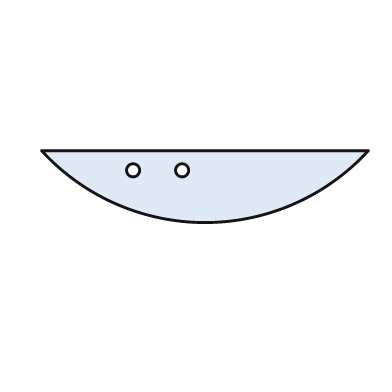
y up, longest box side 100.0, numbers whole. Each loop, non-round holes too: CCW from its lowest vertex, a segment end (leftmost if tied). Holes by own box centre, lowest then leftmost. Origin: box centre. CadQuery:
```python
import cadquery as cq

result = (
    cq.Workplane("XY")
    .moveTo(-50.0, 11.0)
    .threePointArc((0.0, -11.0), (50.0, 11.0))
    .close()
    .moveTo(-22.0, 5.0)
    .circle(2.0)
    .moveTo(-7.0, 5.0)
    .circle(2.0)
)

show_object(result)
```